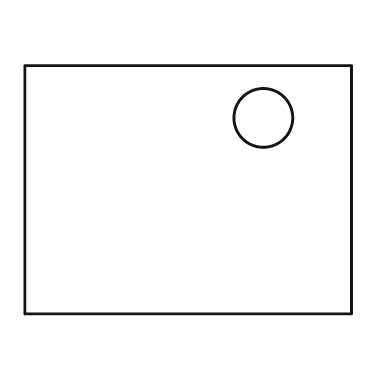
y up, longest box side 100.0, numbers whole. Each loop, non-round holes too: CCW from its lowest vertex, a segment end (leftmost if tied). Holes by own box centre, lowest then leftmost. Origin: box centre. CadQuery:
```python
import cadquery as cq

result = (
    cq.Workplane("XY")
    .moveTo(-50.0, -38.0)
    .lineTo(50.0, -38.0)
    .lineTo(50.0, 38.0)
    .lineTo(-50.0, 38.0)
    .close()
    .moveTo(23.0, 22.0)
    .circle(9.0)
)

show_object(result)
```